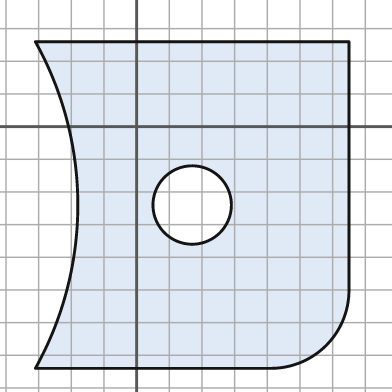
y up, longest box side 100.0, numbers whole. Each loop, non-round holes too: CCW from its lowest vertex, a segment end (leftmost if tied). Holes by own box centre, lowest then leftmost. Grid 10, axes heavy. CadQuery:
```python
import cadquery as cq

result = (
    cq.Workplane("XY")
    .moveTo(-31.0, -74.0)
    .lineTo(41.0, -74.0)
    .threePointArc((58.0, -67.0), (65.0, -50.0))
    .lineTo(65.0, 26.0)
    .lineTo(-31.0, 26.0)
    .threePointArc((-18.0, -24.0), (-31.0, -74.0))
    .close()
    .moveTo(17.0, -24.0)
    .circle(12.0)
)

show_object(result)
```